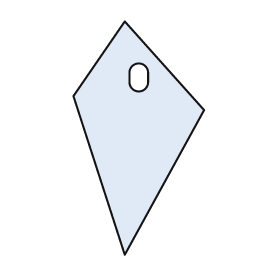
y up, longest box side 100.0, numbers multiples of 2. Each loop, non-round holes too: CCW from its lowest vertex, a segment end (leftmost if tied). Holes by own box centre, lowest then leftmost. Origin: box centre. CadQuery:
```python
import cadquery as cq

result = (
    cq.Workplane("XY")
    .moveTo(-6.0, -50.0)
    .lineTo(28.0, 12.0)
    .lineTo(-6.0, 50.0)
    .lineTo(-28.0, 18.0)
    .close()
    .moveTo(-4.0, 24.0)
    .threePointArc((0.0, 20.0), (4.0, 24.0))
    .lineTo(4.0, 28.0)
    .threePointArc((0.0, 32.0), (-4.0, 28.0))
    .close()
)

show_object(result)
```